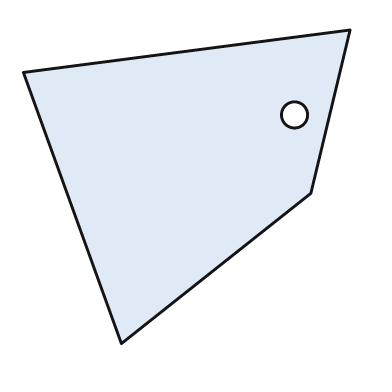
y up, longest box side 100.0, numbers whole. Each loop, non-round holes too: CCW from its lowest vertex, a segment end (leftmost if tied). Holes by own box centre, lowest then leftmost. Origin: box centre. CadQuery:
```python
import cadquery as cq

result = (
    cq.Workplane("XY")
    .moveTo(-20.0, -48.0)
    .lineTo(38.0, -2.0)
    .lineTo(50.0, 48.0)
    .lineTo(-50.0, 35.0)
    .close()
    .moveTo(33.0, 22.0)
    .circle(4.0)
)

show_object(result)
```